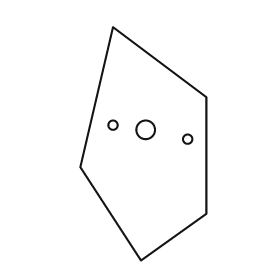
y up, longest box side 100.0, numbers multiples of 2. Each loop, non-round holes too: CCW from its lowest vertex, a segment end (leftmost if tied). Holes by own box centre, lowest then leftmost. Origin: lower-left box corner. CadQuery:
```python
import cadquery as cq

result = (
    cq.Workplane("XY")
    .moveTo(26.0, 0.0)
    .lineTo(54.0, 20.0)
    .lineTo(54.0, 70.0)
    .lineTo(14.0, 100.0)
    .lineTo(0.0, 40.0)
    .close()
    .moveTo(46.0, 52.0)
    .circle(2.0)
    .moveTo(28.0, 56.0)
    .circle(4.0)
    .moveTo(14.0, 58.0)
    .circle(2.0)
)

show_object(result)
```